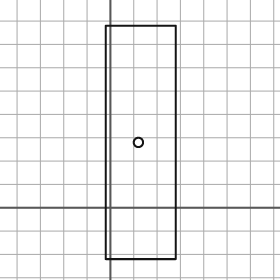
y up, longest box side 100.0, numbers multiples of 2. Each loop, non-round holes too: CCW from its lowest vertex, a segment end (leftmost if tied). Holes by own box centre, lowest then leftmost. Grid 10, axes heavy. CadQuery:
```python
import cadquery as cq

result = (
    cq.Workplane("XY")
    .moveTo(-2.0, -22.0)
    .lineTo(28.0, -22.0)
    .lineTo(28.0, 78.0)
    .lineTo(-2.0, 78.0)
    .close()
    .moveTo(12.0, 28.0)
    .circle(2.0)
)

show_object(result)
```